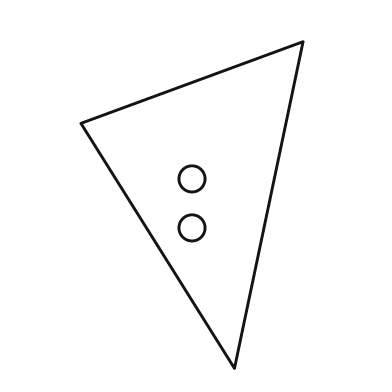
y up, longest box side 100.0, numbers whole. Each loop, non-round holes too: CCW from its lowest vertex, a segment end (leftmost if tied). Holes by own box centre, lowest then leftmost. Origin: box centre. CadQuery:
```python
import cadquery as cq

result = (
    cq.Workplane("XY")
    .moveTo(13.0, -50.0)
    .lineTo(34.0, 50.0)
    .lineTo(-34.0, 25.0)
    .close()
    .moveTo(0.0, -7.0)
    .circle(4.0)
    .moveTo(0.0, 8.0)
    .circle(4.0)
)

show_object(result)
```